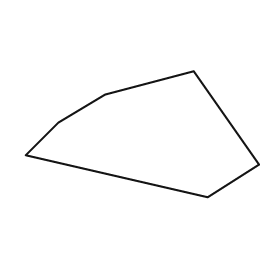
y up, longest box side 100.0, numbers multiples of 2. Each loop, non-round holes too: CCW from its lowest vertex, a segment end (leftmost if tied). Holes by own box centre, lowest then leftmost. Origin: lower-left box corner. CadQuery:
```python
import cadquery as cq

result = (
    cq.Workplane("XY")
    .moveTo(78.0, 0.0)
    .lineTo(100.0, 14.0)
    .lineTo(72.0, 54.0)
    .lineTo(34.0, 44.0)
    .lineTo(14.0, 32.0)
    .lineTo(0.0, 18.0)
    .close()
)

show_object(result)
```